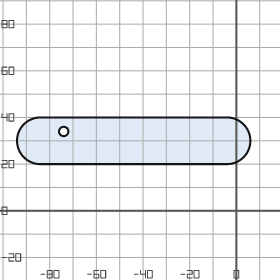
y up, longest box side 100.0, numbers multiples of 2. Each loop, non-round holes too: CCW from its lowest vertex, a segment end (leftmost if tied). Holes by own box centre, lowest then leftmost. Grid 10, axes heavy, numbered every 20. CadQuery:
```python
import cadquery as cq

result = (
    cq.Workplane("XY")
    .moveTo(-84.0, 20.0)
    .lineTo(-4.0, 20.0)
    .threePointArc((6.0, 30.0), (-4.0, 40.0))
    .lineTo(-84.0, 40.0)
    .threePointArc((-94.0, 30.0), (-84.0, 20.0))
    .close()
    .moveTo(-74.0, 34.0)
    .circle(2.0)
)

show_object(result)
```